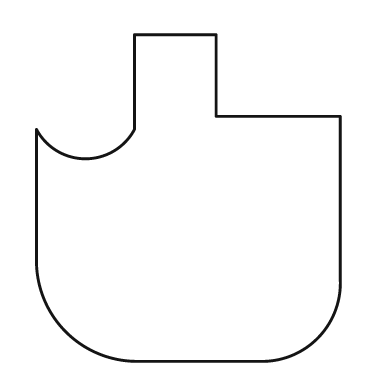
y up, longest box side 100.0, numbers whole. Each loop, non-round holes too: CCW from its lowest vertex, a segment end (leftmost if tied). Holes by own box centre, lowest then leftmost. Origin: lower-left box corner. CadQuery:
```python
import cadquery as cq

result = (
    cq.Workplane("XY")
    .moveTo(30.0, 0.0)
    .lineTo(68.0, 0.0)
    .threePointArc((86.0, 7.0), (93.0, 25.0))
    .lineTo(93.0, 75.0)
    .lineTo(55.0, 75.0)
    .lineTo(55.0, 100.0)
    .lineTo(30.0, 100.0)
    .lineTo(30.0, 71.0)
    .threePointArc((15.0, 62.0), (0.0, 71.0))
    .lineTo(0.0, 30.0)
    .threePointArc((9.0, 9.0), (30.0, 0.0))
    .close()
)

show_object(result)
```